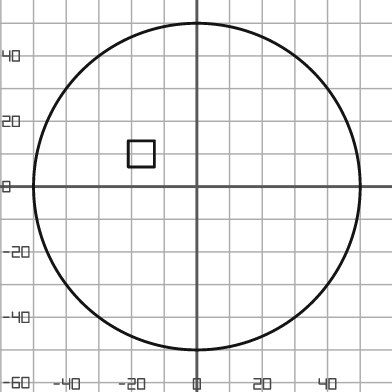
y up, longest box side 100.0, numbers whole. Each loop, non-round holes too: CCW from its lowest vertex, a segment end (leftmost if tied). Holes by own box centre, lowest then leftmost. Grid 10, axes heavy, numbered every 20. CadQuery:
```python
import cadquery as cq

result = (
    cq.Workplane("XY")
    .moveTo(0.0, 0.0)
    .circle(50.0)
    .moveTo(-21.0, 6.0)
    .lineTo(-13.0, 6.0)
    .lineTo(-13.0, 14.0)
    .lineTo(-21.0, 14.0)
    .close()
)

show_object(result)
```